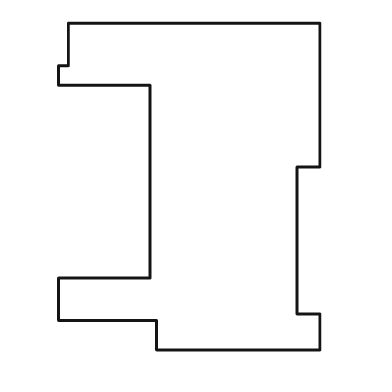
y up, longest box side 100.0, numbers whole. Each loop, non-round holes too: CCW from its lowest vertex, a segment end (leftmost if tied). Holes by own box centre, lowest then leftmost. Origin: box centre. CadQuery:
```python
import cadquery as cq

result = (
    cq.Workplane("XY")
    .moveTo(-10.0, -50.0)
    .lineTo(40.0, -50.0)
    .lineTo(40.0, -39.0)
    .lineTo(33.0, -39.0)
    .lineTo(33.0, 6.0)
    .lineTo(40.0, 6.0)
    .lineTo(40.0, 50.0)
    .lineTo(-37.0, 50.0)
    .lineTo(-37.0, 37.0)
    .lineTo(-40.0, 37.0)
    .lineTo(-40.0, 31.0)
    .lineTo(-12.0, 31.0)
    .lineTo(-12.0, -28.0)
    .lineTo(-40.0, -28.0)
    .lineTo(-40.0, -41.0)
    .lineTo(-10.0, -41.0)
    .close()
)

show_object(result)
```